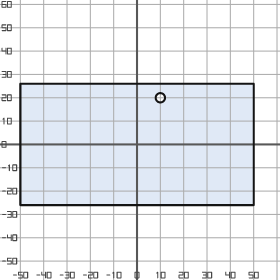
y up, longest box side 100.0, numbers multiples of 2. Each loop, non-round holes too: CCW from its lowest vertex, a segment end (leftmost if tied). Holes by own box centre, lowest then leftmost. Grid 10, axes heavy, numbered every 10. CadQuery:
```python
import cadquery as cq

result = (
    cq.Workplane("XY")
    .moveTo(-50.0, -26.0)
    .lineTo(50.0, -26.0)
    .lineTo(50.0, 26.0)
    .lineTo(-50.0, 26.0)
    .close()
    .moveTo(10.0, 20.0)
    .circle(2.0)
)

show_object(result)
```